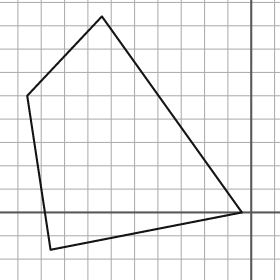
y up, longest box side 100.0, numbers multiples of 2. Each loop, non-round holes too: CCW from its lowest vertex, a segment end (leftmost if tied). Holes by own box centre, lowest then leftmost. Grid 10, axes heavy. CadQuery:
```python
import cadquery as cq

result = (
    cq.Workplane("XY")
    .moveTo(-86.0, -16.0)
    .lineTo(-4.0, 0.0)
    .lineTo(-64.0, 84.0)
    .lineTo(-96.0, 50.0)
    .close()
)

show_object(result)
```